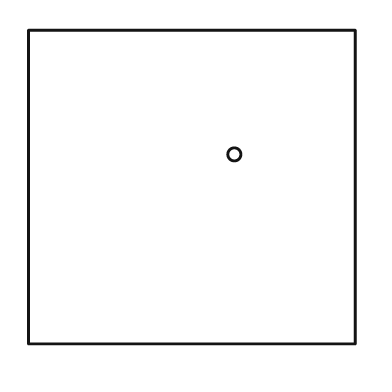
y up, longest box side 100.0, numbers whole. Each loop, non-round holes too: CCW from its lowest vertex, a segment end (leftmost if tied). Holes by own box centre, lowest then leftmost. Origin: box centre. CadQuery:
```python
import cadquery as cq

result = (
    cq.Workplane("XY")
    .moveTo(-50.0, -48.0)
    .lineTo(50.0, -48.0)
    .lineTo(50.0, 48.0)
    .lineTo(-50.0, 48.0)
    .close()
    .moveTo(13.0, 10.0)
    .circle(2.0)
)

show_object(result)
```